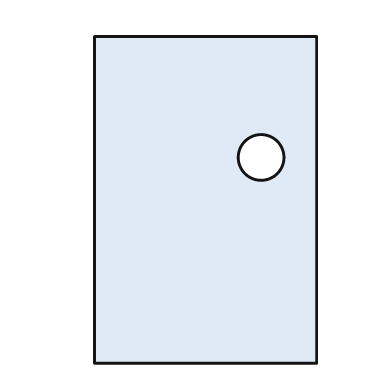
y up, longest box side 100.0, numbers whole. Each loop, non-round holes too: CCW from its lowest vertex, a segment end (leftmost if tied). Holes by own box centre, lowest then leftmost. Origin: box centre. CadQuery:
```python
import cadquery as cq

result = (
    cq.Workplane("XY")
    .moveTo(-34.0, -50.0)
    .lineTo(34.0, -50.0)
    .lineTo(34.0, 50.0)
    .lineTo(-34.0, 50.0)
    .close()
    .moveTo(17.0, 13.0)
    .circle(7.0)
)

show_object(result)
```